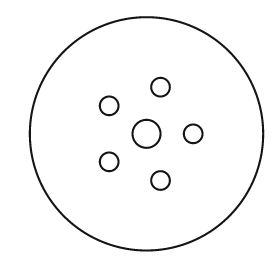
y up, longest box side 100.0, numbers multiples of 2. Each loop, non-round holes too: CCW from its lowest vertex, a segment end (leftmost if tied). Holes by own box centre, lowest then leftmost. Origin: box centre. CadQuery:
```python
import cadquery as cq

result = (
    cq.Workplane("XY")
    .moveTo(0.0, 0.0)
    .circle(50.0)
    .moveTo(6.0, -20.0)
    .circle(4.0)
    .moveTo(-16.0, -12.0)
    .circle(4.0)
    .moveTo(0.0, 0.0)
    .circle(6.0)
    .moveTo(20.0, 0.0)
    .circle(4.0)
    .moveTo(-16.0, 12.0)
    .circle(4.0)
    .moveTo(6.0, 20.0)
    .circle(4.0)
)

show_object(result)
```